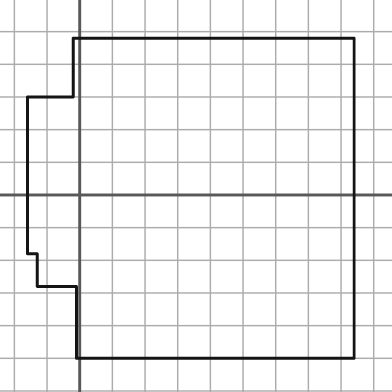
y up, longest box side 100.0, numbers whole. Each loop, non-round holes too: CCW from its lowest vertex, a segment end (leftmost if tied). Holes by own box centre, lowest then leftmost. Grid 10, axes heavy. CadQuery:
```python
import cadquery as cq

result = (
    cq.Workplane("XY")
    .moveTo(-1.0, -50.0)
    .lineTo(84.0, -50.0)
    .lineTo(84.0, 48.0)
    .lineTo(-2.0, 48.0)
    .lineTo(-2.0, 30.0)
    .lineTo(-16.0, 30.0)
    .lineTo(-16.0, -18.0)
    .lineTo(-13.0, -18.0)
    .lineTo(-13.0, -28.0)
    .lineTo(-1.0, -28.0)
    .close()
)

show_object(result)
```